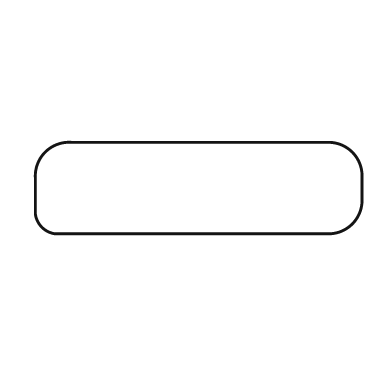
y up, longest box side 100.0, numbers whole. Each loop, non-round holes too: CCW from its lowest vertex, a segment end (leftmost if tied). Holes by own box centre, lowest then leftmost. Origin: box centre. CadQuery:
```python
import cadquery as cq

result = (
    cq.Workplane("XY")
    .moveTo(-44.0, -14.0)
    .lineTo(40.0, -14.0)
    .threePointArc((47.0, -11.0), (50.0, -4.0))
    .lineTo(50.0, 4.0)
    .threePointArc((47.0, 11.0), (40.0, 14.0))
    .lineTo(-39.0, 14.0)
    .threePointArc((-47.0, 11.0), (-50.0, 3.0))
    .lineTo(-50.0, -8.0)
    .threePointArc((-48.0, -12.0), (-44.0, -14.0))
    .close()
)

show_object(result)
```